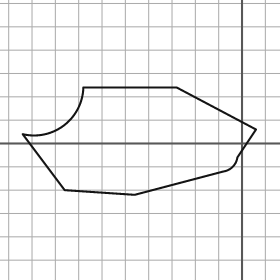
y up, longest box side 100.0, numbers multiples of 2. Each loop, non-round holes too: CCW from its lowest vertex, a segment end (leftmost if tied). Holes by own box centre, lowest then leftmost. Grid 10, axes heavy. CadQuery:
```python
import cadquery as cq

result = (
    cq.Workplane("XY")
    .moveTo(-46.0, -22.0)
    .lineTo(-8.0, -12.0)
    .threePointArc((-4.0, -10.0), (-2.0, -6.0))
    .lineTo(6.0, 6.0)
    .lineTo(-28.0, 24.0)
    .lineTo(-68.0, 24.0)
    .threePointArc((-76.0, 8.0), (-94.0, 4.0))
    .lineTo(-76.0, -20.0)
    .close()
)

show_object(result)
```